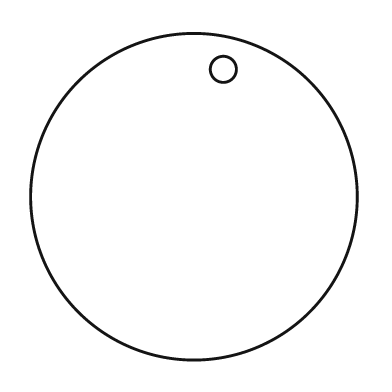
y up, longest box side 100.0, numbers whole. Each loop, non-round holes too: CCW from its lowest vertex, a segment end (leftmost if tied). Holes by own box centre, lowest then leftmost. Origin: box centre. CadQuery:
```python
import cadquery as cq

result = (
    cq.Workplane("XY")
    .moveTo(0.0, 0.0)
    .circle(50.0)
    .moveTo(9.0, 39.0)
    .circle(4.0)
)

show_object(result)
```